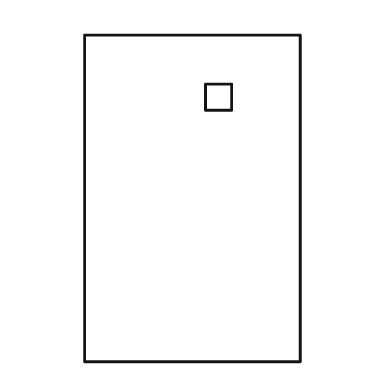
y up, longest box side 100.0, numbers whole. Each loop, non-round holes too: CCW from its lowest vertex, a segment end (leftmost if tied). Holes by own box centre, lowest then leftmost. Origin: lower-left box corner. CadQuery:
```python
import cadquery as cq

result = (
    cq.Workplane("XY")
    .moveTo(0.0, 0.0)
    .lineTo(66.0, 0.0)
    .lineTo(66.0, 100.0)
    .lineTo(0.0, 100.0)
    .close()
    .moveTo(37.0, 77.0)
    .lineTo(45.0, 77.0)
    .lineTo(45.0, 85.0)
    .lineTo(37.0, 85.0)
    .close()
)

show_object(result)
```